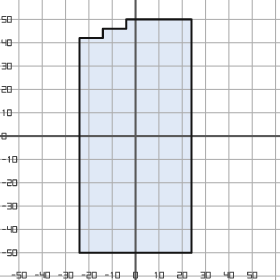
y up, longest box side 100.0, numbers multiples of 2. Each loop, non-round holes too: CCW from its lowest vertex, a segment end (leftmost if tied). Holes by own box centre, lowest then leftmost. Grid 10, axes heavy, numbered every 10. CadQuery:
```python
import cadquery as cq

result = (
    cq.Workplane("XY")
    .moveTo(-24.0, -50.0)
    .lineTo(24.0, -50.0)
    .lineTo(24.0, 50.0)
    .lineTo(-4.0, 50.0)
    .lineTo(-4.0, 46.0)
    .lineTo(-14.0, 46.0)
    .lineTo(-14.0, 42.0)
    .lineTo(-24.0, 42.0)
    .close()
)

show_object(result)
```